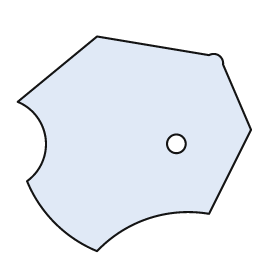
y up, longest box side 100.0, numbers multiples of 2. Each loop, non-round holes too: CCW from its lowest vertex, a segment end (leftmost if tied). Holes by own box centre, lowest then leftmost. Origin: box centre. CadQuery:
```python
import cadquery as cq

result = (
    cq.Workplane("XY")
    .moveTo(-16.0, -46.0)
    .threePointArc((6.0, -32.0), (32.0, -30.0))
    .lineTo(50.0, 6.0)
    .lineTo(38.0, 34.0)
    .threePointArc((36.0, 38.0), (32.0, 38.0))
    .lineTo(-16.0, 46.0)
    .lineTo(-50.0, 18.0)
    .threePointArc((-38.0, 2.0), (-46.0, -16.0))
    .threePointArc((-34.0, -34.0), (-16.0, -46.0))
    .close()
    .moveTo(18.0, 0.0)
    .circle(4.0)
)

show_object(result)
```